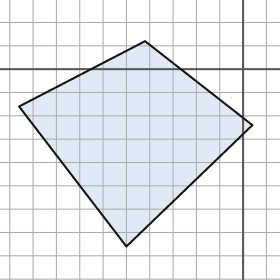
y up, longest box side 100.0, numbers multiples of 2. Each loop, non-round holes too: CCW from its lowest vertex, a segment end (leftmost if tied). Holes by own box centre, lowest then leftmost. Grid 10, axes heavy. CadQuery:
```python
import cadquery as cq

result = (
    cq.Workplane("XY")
    .moveTo(-50.0, -76.0)
    .lineTo(4.0, -24.0)
    .lineTo(-42.0, 12.0)
    .lineTo(-96.0, -16.0)
    .close()
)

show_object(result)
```